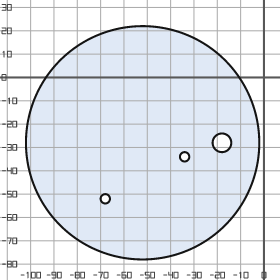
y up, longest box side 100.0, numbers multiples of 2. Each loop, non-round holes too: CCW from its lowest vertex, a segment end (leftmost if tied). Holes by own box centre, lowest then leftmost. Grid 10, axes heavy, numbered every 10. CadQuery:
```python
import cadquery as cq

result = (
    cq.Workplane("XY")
    .moveTo(-52.0, -28.0)
    .circle(50.0)
    .moveTo(-68.0, -52.0)
    .circle(2.0)
    .moveTo(-34.0, -34.0)
    .circle(2.0)
    .moveTo(-18.0, -28.0)
    .circle(4.0)
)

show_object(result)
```